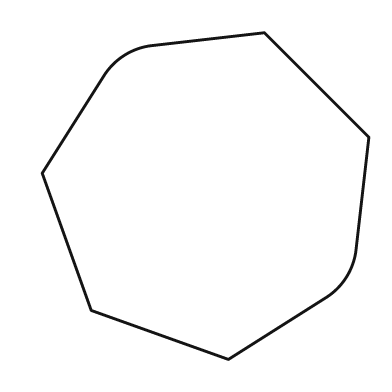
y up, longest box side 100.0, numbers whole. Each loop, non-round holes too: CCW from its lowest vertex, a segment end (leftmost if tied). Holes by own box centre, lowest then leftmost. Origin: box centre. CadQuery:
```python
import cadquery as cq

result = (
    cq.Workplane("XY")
    .moveTo(7.0, -50.0)
    .lineTo(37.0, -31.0)
    .threePointArc((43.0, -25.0), (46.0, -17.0))
    .lineTo(50.0, 18.0)
    .lineTo(18.0, 50.0)
    .lineTo(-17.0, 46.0)
    .threePointArc((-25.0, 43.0), (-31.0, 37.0))
    .lineTo(-50.0, 7.0)
    .lineTo(-35.0, -35.0)
    .close()
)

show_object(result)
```